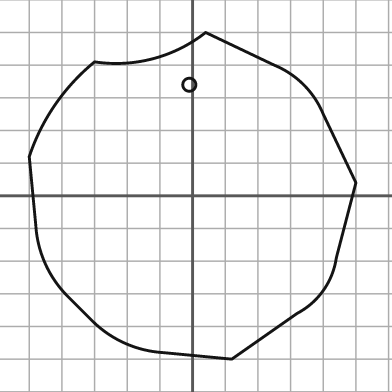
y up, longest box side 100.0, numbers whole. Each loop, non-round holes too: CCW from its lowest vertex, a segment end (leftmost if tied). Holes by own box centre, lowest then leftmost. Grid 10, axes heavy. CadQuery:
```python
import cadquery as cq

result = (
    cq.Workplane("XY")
    .moveTo(12.0, -50.0)
    .lineTo(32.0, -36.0)
    .threePointArc((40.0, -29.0), (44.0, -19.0))
    .lineTo(50.0, 4.0)
    .lineTo(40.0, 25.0)
    .threePointArc((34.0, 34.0), (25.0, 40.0))
    .lineTo(4.0, 50.0)
    .threePointArc((-12.0, 42.0), (-30.0, 41.0))
    .threePointArc((-42.0, 28.0), (-50.0, 12.0))
    .lineTo(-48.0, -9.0)
    .threePointArc((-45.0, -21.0), (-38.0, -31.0))
    .lineTo(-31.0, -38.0)
    .threePointArc((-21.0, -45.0), (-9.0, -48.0))
    .close()
    .moveTo(-1.0, 34.0)
    .circle(2.0)
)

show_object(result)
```